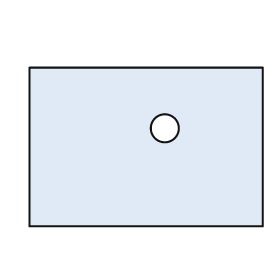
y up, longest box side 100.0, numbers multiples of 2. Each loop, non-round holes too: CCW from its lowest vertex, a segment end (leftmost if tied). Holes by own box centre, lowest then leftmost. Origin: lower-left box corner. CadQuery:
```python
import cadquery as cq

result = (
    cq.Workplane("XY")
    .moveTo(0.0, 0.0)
    .lineTo(100.0, 0.0)
    .lineTo(100.0, 68.0)
    .lineTo(0.0, 68.0)
    .close()
    .moveTo(58.0, 42.0)
    .circle(6.0)
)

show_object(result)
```